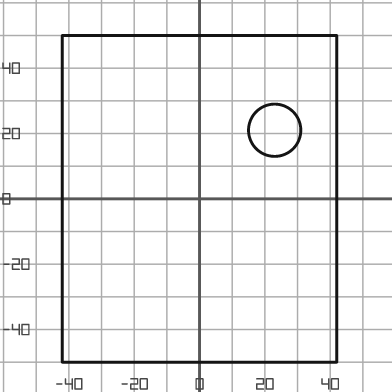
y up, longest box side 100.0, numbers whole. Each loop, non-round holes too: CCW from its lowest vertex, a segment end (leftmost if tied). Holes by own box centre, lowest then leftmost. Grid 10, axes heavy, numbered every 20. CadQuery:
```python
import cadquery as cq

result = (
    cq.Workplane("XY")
    .moveTo(-42.0, -50.0)
    .lineTo(42.0, -50.0)
    .lineTo(42.0, 50.0)
    .lineTo(-42.0, 50.0)
    .close()
    .moveTo(23.0, 21.0)
    .circle(8.0)
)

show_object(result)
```